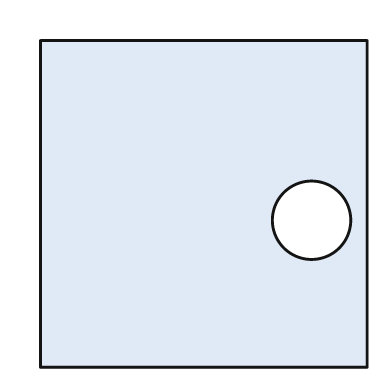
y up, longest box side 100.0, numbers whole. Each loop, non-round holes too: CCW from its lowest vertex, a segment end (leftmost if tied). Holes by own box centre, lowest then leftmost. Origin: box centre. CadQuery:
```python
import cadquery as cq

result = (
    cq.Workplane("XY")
    .moveTo(-50.0, -50.0)
    .lineTo(50.0, -50.0)
    .lineTo(50.0, 50.0)
    .lineTo(-50.0, 50.0)
    .close()
    .moveTo(33.0, -5.0)
    .circle(12.0)
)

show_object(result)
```